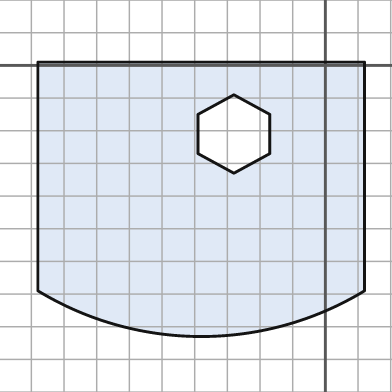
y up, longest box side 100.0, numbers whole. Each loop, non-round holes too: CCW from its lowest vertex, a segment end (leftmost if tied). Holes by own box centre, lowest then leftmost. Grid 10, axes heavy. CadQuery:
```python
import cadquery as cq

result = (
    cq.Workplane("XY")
    .moveTo(-88.0, -69.0)
    .threePointArc((-38.0, -83.0), (12.0, -69.0))
    .lineTo(12.0, 1.0)
    .lineTo(-88.0, 1.0)
    .close()
    .moveTo(-28.0, -33.0)
    .lineTo(-17.0, -27.0)
    .lineTo(-17.0, -15.0)
    .lineTo(-28.0, -9.0)
    .lineTo(-39.0, -15.0)
    .lineTo(-39.0, -27.0)
    .close()
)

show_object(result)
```